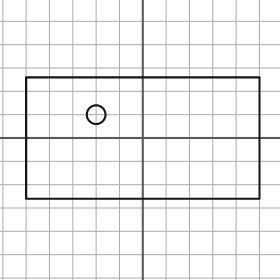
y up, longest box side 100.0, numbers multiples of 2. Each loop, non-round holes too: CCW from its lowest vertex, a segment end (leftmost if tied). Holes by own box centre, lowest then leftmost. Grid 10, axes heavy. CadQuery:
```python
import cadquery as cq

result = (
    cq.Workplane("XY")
    .moveTo(-50.0, -26.0)
    .lineTo(50.0, -26.0)
    .lineTo(50.0, 26.0)
    .lineTo(-50.0, 26.0)
    .close()
    .moveTo(-20.0, 10.0)
    .circle(4.0)
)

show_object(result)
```